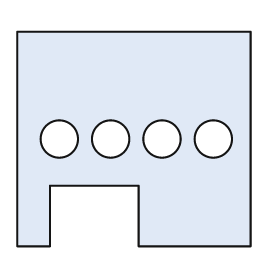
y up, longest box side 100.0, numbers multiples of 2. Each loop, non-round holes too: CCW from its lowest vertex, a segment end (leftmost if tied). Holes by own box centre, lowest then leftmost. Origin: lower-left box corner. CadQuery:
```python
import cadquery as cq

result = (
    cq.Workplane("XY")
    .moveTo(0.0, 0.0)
    .lineTo(14.0, 0.0)
    .lineTo(14.0, 26.0)
    .lineTo(52.0, 26.0)
    .lineTo(52.0, 0.0)
    .lineTo(100.0, 0.0)
    .lineTo(100.0, 92.0)
    .lineTo(0.0, 92.0)
    .close()
    .moveTo(18.0, 46.0)
    .circle(8.0)
    .moveTo(40.0, 46.0)
    .circle(8.0)
    .moveTo(62.0, 46.0)
    .circle(8.0)
    .moveTo(84.0, 46.0)
    .circle(8.0)
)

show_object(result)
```